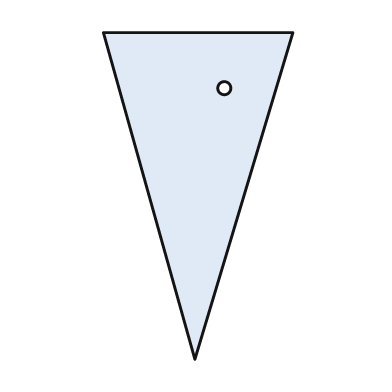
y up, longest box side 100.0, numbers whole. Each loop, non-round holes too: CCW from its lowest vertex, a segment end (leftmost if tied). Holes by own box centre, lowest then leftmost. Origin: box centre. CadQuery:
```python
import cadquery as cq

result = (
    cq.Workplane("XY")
    .moveTo(-1.0, -50.0)
    .lineTo(29.0, 50.0)
    .lineTo(-29.0, 50.0)
    .close()
    .moveTo(8.0, 33.0)
    .circle(2.0)
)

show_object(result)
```